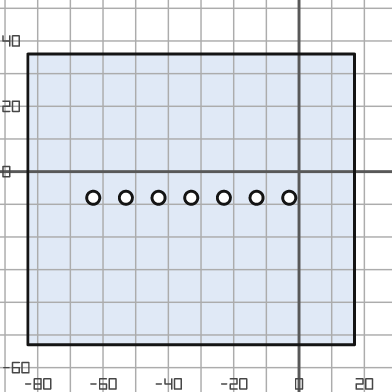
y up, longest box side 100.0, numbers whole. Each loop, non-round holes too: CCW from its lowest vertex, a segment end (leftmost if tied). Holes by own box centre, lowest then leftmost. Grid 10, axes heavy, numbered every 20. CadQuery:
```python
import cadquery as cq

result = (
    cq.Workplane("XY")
    .moveTo(-83.0, -53.0)
    .lineTo(17.0, -53.0)
    .lineTo(17.0, 36.0)
    .lineTo(-83.0, 36.0)
    .close()
    .moveTo(-63.0, -8.0)
    .circle(2.0)
    .moveTo(-53.0, -8.0)
    .circle(2.0)
    .moveTo(-43.0, -8.0)
    .circle(2.0)
    .moveTo(-33.0, -8.0)
    .circle(2.0)
    .moveTo(-23.0, -8.0)
    .circle(2.0)
    .moveTo(-13.0, -8.0)
    .circle(2.0)
    .moveTo(-3.0, -8.0)
    .circle(2.0)
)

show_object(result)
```